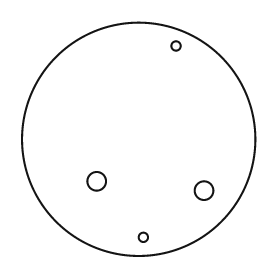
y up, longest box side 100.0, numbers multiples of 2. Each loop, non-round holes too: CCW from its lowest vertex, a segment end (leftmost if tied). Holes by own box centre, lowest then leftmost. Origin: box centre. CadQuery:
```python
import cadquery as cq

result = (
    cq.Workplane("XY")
    .moveTo(0.0, 0.0)
    .circle(50.0)
    .moveTo(2.0, -42.0)
    .circle(2.0)
    .moveTo(28.0, -22.0)
    .circle(4.0)
    .moveTo(-18.0, -18.0)
    .circle(4.0)
    .moveTo(16.0, 40.0)
    .circle(2.0)
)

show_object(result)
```